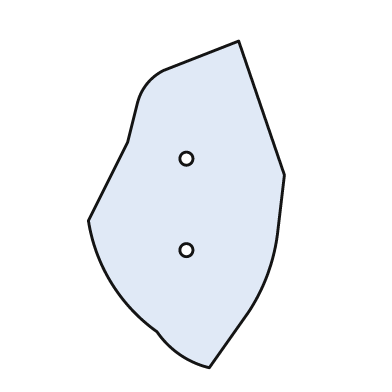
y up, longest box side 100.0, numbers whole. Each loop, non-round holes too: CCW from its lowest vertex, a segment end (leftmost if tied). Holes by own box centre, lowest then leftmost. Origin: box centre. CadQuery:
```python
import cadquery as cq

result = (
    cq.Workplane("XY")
    .moveTo(7.0, -50.0)
    .lineTo(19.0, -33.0)
    .threePointArc((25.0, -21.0), (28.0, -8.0))
    .lineTo(30.0, 9.0)
    .lineTo(16.0, 50.0)
    .lineTo(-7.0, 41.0)
    .threePointArc((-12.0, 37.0), (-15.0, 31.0))
    .lineTo(-18.0, 19.0)
    .lineTo(-30.0, -5.0)
    .threePointArc((-23.0, -24.0), (-9.0, -39.0))
    .threePointArc((-2.0, -46.0), (7.0, -50.0))
    .close()
    .moveTo(0.0, -14.0)
    .circle(2.0)
    .moveTo(0.0, 14.0)
    .circle(2.0)
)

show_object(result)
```